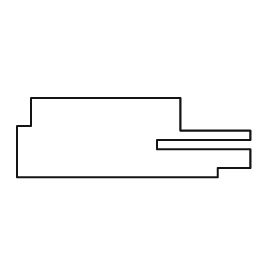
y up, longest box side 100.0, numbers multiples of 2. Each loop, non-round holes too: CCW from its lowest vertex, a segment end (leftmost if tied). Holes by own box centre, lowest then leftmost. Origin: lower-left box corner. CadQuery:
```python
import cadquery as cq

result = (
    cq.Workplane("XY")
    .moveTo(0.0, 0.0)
    .lineTo(86.0, 0.0)
    .lineTo(86.0, 4.0)
    .lineTo(100.0, 4.0)
    .lineTo(100.0, 12.0)
    .lineTo(60.0, 12.0)
    .lineTo(60.0, 16.0)
    .lineTo(100.0, 16.0)
    .lineTo(100.0, 20.0)
    .lineTo(70.0, 20.0)
    .lineTo(70.0, 34.0)
    .lineTo(6.0, 34.0)
    .lineTo(6.0, 22.0)
    .lineTo(0.0, 22.0)
    .close()
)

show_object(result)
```